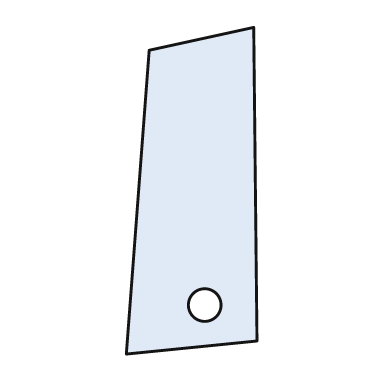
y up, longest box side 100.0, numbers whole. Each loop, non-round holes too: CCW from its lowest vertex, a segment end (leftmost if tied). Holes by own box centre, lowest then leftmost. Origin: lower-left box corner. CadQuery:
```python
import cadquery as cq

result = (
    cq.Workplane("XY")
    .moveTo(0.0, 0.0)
    .lineTo(40.0, 4.0)
    .lineTo(39.0, 100.0)
    .lineTo(7.0, 93.0)
    .close()
    .moveTo(24.0, 15.0)
    .circle(5.0)
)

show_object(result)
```